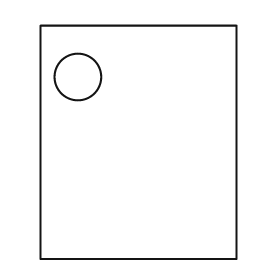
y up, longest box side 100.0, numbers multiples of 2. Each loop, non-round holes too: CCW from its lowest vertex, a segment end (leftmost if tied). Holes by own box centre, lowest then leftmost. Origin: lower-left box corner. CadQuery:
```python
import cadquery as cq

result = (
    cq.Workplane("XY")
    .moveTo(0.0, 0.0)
    .lineTo(84.0, 0.0)
    .lineTo(84.0, 100.0)
    .lineTo(0.0, 100.0)
    .close()
    .moveTo(16.0, 78.0)
    .circle(10.0)
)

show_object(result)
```